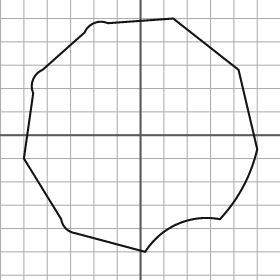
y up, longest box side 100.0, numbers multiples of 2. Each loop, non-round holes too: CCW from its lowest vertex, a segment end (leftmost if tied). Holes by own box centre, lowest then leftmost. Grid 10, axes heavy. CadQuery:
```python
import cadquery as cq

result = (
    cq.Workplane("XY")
    .moveTo(2.0, -50.0)
    .threePointArc((16.0, -38.0), (34.0, -36.0))
    .threePointArc((44.0, -22.0), (50.0, -6.0))
    .lineTo(42.0, 28.0)
    .lineTo(14.0, 50.0)
    .lineTo(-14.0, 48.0)
    .threePointArc((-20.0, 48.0), (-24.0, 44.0))
    .lineTo(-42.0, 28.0)
    .threePointArc((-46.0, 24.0), (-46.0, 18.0))
    .lineTo(-50.0, -10.0)
    .lineTo(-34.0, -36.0)
    .threePointArc((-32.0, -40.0), (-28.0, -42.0))
    .close()
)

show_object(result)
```